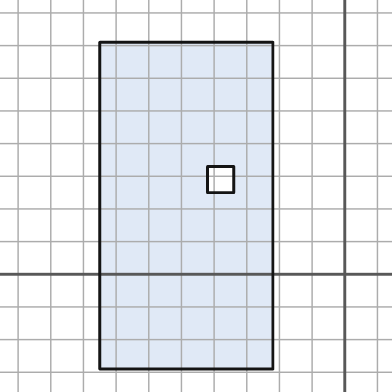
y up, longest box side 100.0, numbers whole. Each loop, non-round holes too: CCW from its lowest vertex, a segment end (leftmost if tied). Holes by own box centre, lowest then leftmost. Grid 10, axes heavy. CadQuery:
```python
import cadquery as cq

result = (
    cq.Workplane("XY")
    .moveTo(-75.0, -29.0)
    .lineTo(-22.0, -29.0)
    .lineTo(-22.0, 71.0)
    .lineTo(-75.0, 71.0)
    .close()
    .moveTo(-42.0, 25.0)
    .lineTo(-34.0, 25.0)
    .lineTo(-34.0, 33.0)
    .lineTo(-42.0, 33.0)
    .close()
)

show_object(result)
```